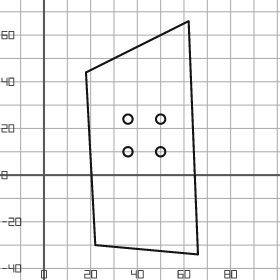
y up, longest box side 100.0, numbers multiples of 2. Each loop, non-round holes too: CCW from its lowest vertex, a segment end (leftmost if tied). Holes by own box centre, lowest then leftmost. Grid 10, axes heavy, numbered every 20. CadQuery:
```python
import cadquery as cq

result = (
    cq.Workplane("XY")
    .moveTo(66.0, -34.0)
    .lineTo(62.0, 66.0)
    .lineTo(18.0, 44.0)
    .lineTo(22.0, -30.0)
    .close()
    .moveTo(36.0, 10.0)
    .circle(2.0)
    .moveTo(50.0, 10.0)
    .circle(2.0)
    .moveTo(36.0, 24.0)
    .circle(2.0)
    .moveTo(50.0, 24.0)
    .circle(2.0)
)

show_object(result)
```